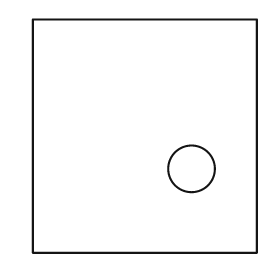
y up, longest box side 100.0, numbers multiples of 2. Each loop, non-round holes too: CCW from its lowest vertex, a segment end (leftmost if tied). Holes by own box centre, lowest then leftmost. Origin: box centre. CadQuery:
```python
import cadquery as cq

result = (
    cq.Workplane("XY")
    .moveTo(-48.0, -50.0)
    .lineTo(48.0, -50.0)
    .lineTo(48.0, 50.0)
    .lineTo(-48.0, 50.0)
    .close()
    .moveTo(20.0, -14.0)
    .circle(10.0)
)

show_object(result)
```